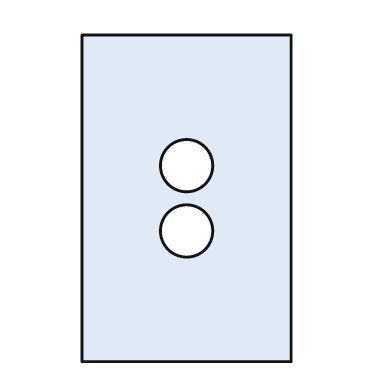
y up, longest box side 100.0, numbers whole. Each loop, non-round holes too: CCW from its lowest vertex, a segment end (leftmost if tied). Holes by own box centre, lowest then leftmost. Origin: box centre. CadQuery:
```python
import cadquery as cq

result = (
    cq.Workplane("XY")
    .moveTo(-32.0, -50.0)
    .lineTo(32.0, -50.0)
    .lineTo(32.0, 50.0)
    .lineTo(-32.0, 50.0)
    .close()
    .moveTo(0.0, -10.0)
    .circle(8.0)
    .moveTo(0.0, 10.0)
    .circle(8.0)
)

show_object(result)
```